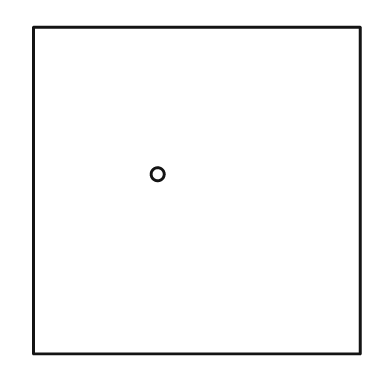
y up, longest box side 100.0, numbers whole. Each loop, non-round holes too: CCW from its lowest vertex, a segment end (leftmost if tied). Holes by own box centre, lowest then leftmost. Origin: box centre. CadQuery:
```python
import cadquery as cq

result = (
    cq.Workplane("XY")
    .moveTo(-50.0, -50.0)
    .lineTo(50.0, -50.0)
    .lineTo(50.0, 50.0)
    .lineTo(-50.0, 50.0)
    .close()
    .moveTo(-12.0, 5.0)
    .circle(2.0)
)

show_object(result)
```